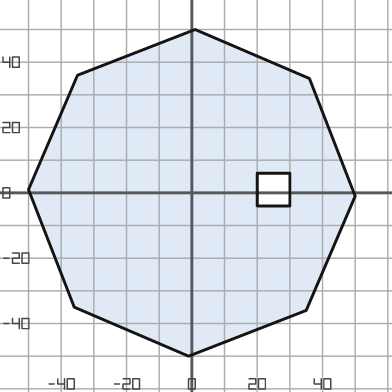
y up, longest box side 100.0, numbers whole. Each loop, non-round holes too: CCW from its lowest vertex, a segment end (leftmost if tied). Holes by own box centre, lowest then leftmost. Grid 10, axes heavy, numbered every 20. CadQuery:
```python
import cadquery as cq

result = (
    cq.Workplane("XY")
    .moveTo(-1.0, -50.0)
    .lineTo(35.0, -36.0)
    .lineTo(50.0, -1.0)
    .lineTo(36.0, 35.0)
    .lineTo(1.0, 50.0)
    .lineTo(-35.0, 36.0)
    .lineTo(-50.0, 1.0)
    .lineTo(-36.0, -35.0)
    .close()
    .moveTo(20.0, -4.0)
    .lineTo(30.0, -4.0)
    .lineTo(30.0, 6.0)
    .lineTo(20.0, 6.0)
    .close()
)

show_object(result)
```